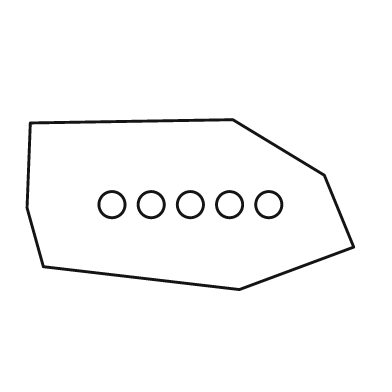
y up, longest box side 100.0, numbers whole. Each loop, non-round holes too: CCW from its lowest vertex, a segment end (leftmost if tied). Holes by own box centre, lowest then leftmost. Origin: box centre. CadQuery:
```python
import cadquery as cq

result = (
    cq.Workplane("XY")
    .moveTo(15.0, -26.0)
    .lineTo(50.0, -13.0)
    .lineTo(41.0, 9.0)
    .lineTo(13.0, 26.0)
    .lineTo(-49.0, 25.0)
    .lineTo(-50.0, -1.0)
    .lineTo(-45.0, -19.0)
    .close()
    .moveTo(-24.0, 0.0)
    .circle(4.0)
    .moveTo(-12.0, 0.0)
    .circle(4.0)
    .moveTo(0.0, 0.0)
    .circle(4.0)
    .moveTo(12.0, 0.0)
    .circle(4.0)
    .moveTo(24.0, 0.0)
    .circle(4.0)
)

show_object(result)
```